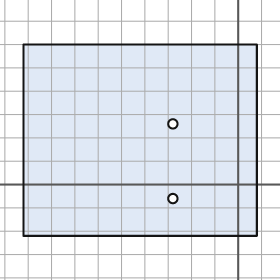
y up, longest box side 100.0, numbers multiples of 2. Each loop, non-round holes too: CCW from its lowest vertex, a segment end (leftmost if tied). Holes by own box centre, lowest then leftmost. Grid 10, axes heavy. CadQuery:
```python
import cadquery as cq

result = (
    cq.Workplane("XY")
    .moveTo(-92.0, -22.0)
    .lineTo(8.0, -22.0)
    .lineTo(8.0, 60.0)
    .lineTo(-92.0, 60.0)
    .close()
    .moveTo(-28.0, -6.0)
    .circle(2.0)
    .moveTo(-28.0, 26.0)
    .circle(2.0)
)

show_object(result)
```